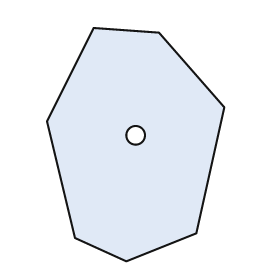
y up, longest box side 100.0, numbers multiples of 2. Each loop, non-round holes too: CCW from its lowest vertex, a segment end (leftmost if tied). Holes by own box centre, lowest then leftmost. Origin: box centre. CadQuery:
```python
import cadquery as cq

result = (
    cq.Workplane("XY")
    .moveTo(-4.0, -50.0)
    .lineTo(26.0, -38.0)
    .lineTo(38.0, 16.0)
    .lineTo(10.0, 48.0)
    .lineTo(-18.0, 50.0)
    .lineTo(-38.0, 10.0)
    .lineTo(-26.0, -40.0)
    .close()
    .moveTo(0.0, 4.0)
    .circle(4.0)
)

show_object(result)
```